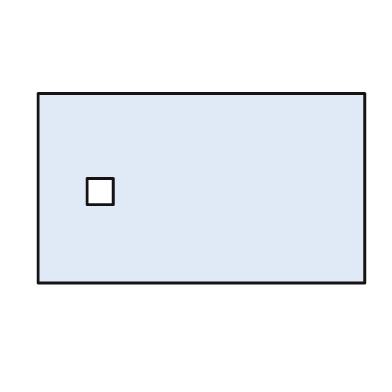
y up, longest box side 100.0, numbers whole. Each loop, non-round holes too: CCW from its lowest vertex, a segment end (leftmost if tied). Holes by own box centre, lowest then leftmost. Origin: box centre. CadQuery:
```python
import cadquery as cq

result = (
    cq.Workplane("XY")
    .moveTo(-50.0, -29.0)
    .lineTo(50.0, -29.0)
    .lineTo(50.0, 29.0)
    .lineTo(-50.0, 29.0)
    .close()
    .moveTo(-35.0, -5.0)
    .lineTo(-27.0, -5.0)
    .lineTo(-27.0, 3.0)
    .lineTo(-35.0, 3.0)
    .close()
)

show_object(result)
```